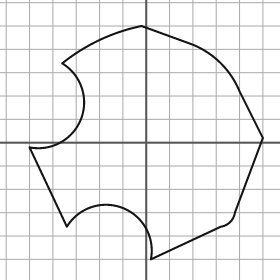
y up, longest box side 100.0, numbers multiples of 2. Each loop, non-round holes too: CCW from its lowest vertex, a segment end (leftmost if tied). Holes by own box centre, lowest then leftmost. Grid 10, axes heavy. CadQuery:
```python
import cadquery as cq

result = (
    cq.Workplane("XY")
    .moveTo(2.0, -50.0)
    .lineTo(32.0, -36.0)
    .threePointArc((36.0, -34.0), (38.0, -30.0))
    .lineTo(50.0, 2.0)
    .lineTo(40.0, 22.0)
    .threePointArc((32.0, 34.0), (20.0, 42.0))
    .lineTo(-2.0, 50.0)
    .threePointArc((-20.0, 44.0), (-36.0, 34.0))
    .threePointArc((-28.0, 10.0), (-50.0, -2.0))
    .lineTo(-34.0, -36.0)
    .threePointArc((-10.0, -28.0), (2.0, -50.0))
    .close()
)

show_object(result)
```